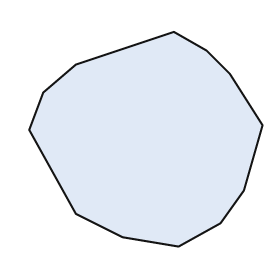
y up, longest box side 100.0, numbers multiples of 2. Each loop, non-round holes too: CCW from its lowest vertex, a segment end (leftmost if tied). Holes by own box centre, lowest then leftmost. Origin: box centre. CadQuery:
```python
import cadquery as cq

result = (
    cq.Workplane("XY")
    .moveTo(14.0, -46.0)
    .lineTo(32.0, -36.0)
    .lineTo(42.0, -22.0)
    .lineTo(50.0, 6.0)
    .lineTo(36.0, 28.0)
    .lineTo(26.0, 38.0)
    .lineTo(12.0, 46.0)
    .lineTo(-30.0, 32.0)
    .lineTo(-44.0, 20.0)
    .lineTo(-50.0, 4.0)
    .lineTo(-30.0, -32.0)
    .lineTo(-10.0, -42.0)
    .close()
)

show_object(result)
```